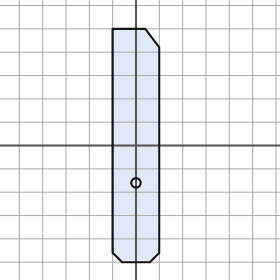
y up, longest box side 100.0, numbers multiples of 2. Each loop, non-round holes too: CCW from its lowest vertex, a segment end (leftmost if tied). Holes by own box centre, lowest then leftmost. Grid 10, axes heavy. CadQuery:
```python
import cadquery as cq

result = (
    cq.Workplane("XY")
    .moveTo(-6.0, -50.0)
    .lineTo(6.0, -50.0)
    .lineTo(10.0, -46.0)
    .lineTo(10.0, 42.0)
    .lineTo(4.0, 50.0)
    .lineTo(-10.0, 50.0)
    .lineTo(-10.0, -46.0)
    .close()
    .moveTo(0.0, -16.0)
    .circle(2.0)
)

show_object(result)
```